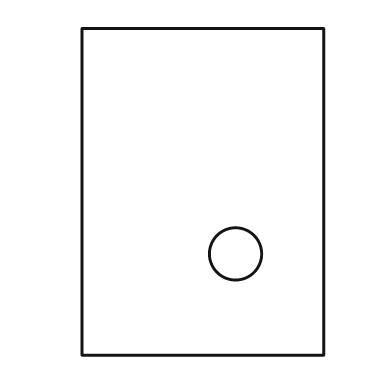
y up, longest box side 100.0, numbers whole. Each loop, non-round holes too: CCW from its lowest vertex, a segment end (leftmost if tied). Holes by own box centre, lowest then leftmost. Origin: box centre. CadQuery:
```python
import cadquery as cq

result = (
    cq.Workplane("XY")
    .moveTo(-37.0, -50.0)
    .lineTo(37.0, -50.0)
    .lineTo(37.0, 50.0)
    .lineTo(-37.0, 50.0)
    .close()
    .moveTo(10.0, -19.0)
    .circle(8.0)
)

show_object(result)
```